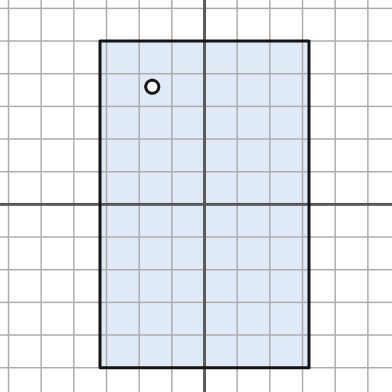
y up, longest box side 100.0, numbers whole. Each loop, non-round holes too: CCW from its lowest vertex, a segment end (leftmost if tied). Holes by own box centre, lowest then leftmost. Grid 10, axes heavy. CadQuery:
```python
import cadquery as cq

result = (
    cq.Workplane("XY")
    .moveTo(-32.0, -50.0)
    .lineTo(32.0, -50.0)
    .lineTo(32.0, 50.0)
    .lineTo(-32.0, 50.0)
    .close()
    .moveTo(-16.0, 36.0)
    .circle(2.0)
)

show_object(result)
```